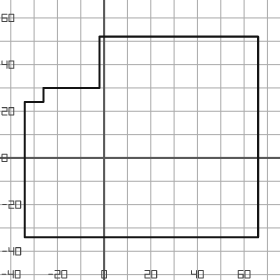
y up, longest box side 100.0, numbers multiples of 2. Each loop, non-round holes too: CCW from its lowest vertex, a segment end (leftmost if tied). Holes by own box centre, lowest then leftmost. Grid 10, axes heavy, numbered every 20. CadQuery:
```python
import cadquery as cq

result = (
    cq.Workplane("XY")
    .moveTo(-34.0, -34.0)
    .lineTo(66.0, -34.0)
    .lineTo(66.0, 52.0)
    .lineTo(-2.0, 52.0)
    .lineTo(-2.0, 30.0)
    .lineTo(-26.0, 30.0)
    .lineTo(-26.0, 24.0)
    .lineTo(-34.0, 24.0)
    .close()
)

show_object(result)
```